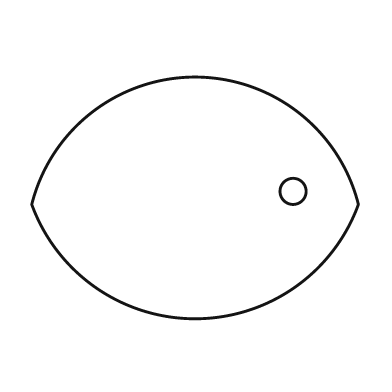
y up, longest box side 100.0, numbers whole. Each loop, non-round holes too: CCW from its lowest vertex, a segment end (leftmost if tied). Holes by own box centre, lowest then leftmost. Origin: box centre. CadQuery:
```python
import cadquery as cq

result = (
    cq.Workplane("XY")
    .moveTo(-50.0, -2.0)
    .threePointArc((0.0, -37.0), (50.0, -2.0))
    .threePointArc((0.0, 37.0), (-50.0, -2.0))
    .close()
    .moveTo(30.0, 2.0)
    .circle(4.0)
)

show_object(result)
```